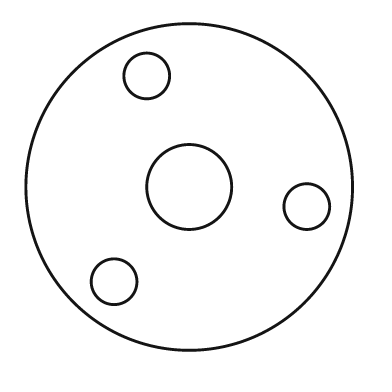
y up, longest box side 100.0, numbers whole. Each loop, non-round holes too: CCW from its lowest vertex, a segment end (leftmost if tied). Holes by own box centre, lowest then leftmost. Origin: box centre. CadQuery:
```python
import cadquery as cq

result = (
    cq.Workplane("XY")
    .moveTo(0.0, 0.0)
    .circle(50.0)
    .moveTo(-23.0, -29.0)
    .circle(7.0)
    .moveTo(36.0, -6.0)
    .circle(7.0)
    .moveTo(0.0, 0.0)
    .circle(13.0)
    .moveTo(-13.0, 34.0)
    .circle(7.0)
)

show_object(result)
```